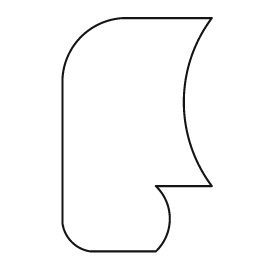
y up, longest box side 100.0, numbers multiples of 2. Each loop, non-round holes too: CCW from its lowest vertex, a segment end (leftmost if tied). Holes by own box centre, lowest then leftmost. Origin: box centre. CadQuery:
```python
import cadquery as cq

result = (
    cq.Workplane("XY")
    .moveTo(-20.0, -50.0)
    .lineTo(8.0, -50.0)
    .threePointArc((14.0, -36.0), (8.0, -22.0))
    .lineTo(32.0, -22.0)
    .threePointArc((20.0, 14.0), (32.0, 50.0))
    .lineTo(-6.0, 50.0)
    .threePointArc((-24.0, 42.0), (-32.0, 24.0))
    .lineTo(-32.0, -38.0)
    .threePointArc((-28.0, -46.0), (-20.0, -50.0))
    .close()
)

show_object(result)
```